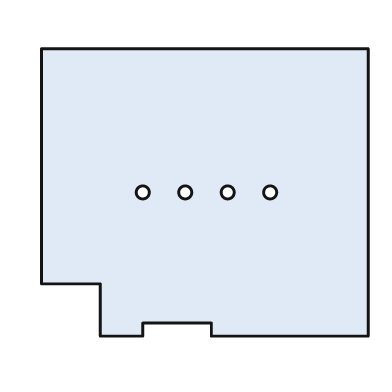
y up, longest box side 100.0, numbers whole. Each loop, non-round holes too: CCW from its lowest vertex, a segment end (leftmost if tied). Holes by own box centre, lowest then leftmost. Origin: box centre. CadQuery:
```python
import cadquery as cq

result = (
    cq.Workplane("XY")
    .moveTo(-32.0, -44.0)
    .lineTo(-19.0, -44.0)
    .lineTo(-19.0, -40.0)
    .lineTo(2.0, -40.0)
    .lineTo(2.0, -44.0)
    .lineTo(50.0, -44.0)
    .lineTo(50.0, 44.0)
    .lineTo(-50.0, 44.0)
    .lineTo(-50.0, -28.0)
    .lineTo(-32.0, -28.0)
    .close()
    .moveTo(-19.0, 0.0)
    .circle(2.0)
    .moveTo(-6.0, 0.0)
    .circle(2.0)
    .moveTo(7.0, 0.0)
    .circle(2.0)
    .moveTo(20.0, 0.0)
    .circle(2.0)
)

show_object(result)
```